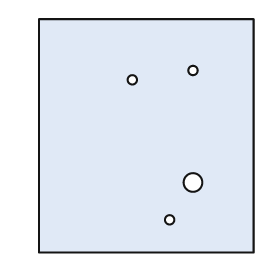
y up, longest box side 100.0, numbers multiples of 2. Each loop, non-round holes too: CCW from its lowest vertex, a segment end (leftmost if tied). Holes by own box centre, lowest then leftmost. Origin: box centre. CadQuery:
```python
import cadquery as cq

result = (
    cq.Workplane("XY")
    .moveTo(-46.0, -50.0)
    .lineTo(46.0, -50.0)
    .lineTo(46.0, 50.0)
    .lineTo(-46.0, 50.0)
    .close()
    .moveTo(10.0, -36.0)
    .circle(2.0)
    .moveTo(20.0, -20.0)
    .circle(4.0)
    .moveTo(-6.0, 24.0)
    .circle(2.0)
    .moveTo(20.0, 28.0)
    .circle(2.0)
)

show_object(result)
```